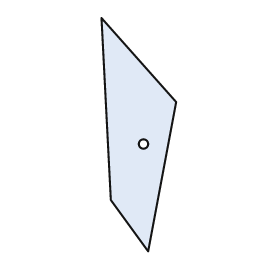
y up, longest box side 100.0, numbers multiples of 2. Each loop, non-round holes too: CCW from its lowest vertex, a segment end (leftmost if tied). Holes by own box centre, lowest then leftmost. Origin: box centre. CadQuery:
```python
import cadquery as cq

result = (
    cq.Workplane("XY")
    .moveTo(4.0, -50.0)
    .lineTo(16.0, 14.0)
    .lineTo(-16.0, 50.0)
    .lineTo(-12.0, -28.0)
    .close()
    .moveTo(2.0, -4.0)
    .circle(2.0)
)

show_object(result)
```